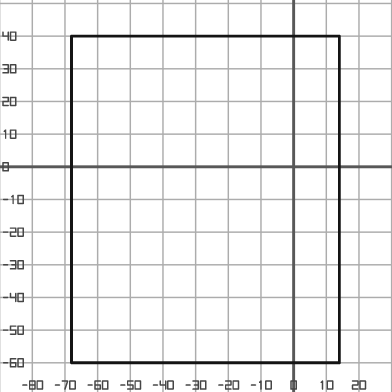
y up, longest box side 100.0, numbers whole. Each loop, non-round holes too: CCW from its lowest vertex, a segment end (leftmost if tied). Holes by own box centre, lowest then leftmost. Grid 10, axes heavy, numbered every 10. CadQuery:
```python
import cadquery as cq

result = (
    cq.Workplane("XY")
    .moveTo(-68.0, -60.0)
    .lineTo(14.0, -60.0)
    .lineTo(14.0, 40.0)
    .lineTo(-68.0, 40.0)
    .close()
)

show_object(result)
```